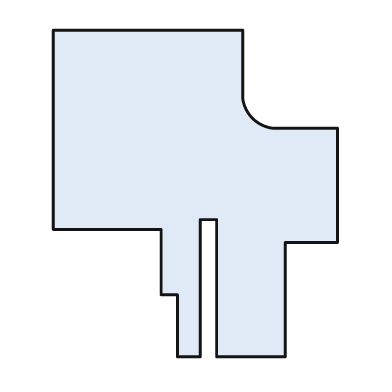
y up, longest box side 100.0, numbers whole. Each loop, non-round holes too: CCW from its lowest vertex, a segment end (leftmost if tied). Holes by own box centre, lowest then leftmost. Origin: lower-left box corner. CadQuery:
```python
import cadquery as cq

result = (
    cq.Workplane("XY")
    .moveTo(38.0, 0.0)
    .lineTo(45.0, 0.0)
    .lineTo(45.0, 42.0)
    .lineTo(50.0, 42.0)
    .lineTo(50.0, 0.0)
    .lineTo(71.0, 0.0)
    .lineTo(71.0, 35.0)
    .lineTo(87.0, 35.0)
    .lineTo(87.0, 70.0)
    .lineTo(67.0, 70.0)
    .threePointArc((61.0, 73.0), (58.0, 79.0))
    .lineTo(58.0, 100.0)
    .lineTo(0.0, 100.0)
    .lineTo(0.0, 39.0)
    .lineTo(33.0, 39.0)
    .lineTo(33.0, 19.0)
    .lineTo(38.0, 19.0)
    .close()
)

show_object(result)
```